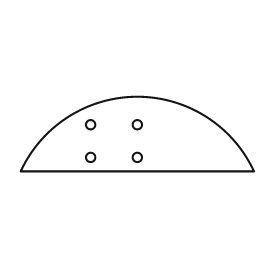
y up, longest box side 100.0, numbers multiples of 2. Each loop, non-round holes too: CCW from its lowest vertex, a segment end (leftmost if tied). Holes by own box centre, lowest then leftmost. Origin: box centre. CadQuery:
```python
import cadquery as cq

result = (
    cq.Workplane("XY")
    .moveTo(-50.0, -16.0)
    .lineTo(50.0, -16.0)
    .threePointArc((0.0, 16.0), (-50.0, -16.0))
    .close()
    .moveTo(-20.0, -10.0)
    .circle(2.0)
    .moveTo(0.0, -10.0)
    .circle(2.0)
    .moveTo(-20.0, 4.0)
    .circle(2.0)
    .moveTo(0.0, 4.0)
    .circle(2.0)
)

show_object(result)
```